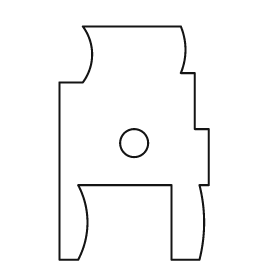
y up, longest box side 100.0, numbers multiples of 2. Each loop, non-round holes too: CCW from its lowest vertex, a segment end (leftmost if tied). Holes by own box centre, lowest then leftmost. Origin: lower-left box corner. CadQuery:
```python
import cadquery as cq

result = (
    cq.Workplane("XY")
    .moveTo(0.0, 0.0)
    .lineTo(8.0, 0.0)
    .threePointArc((12.0, 16.0), (8.0, 32.0))
    .lineTo(48.0, 32.0)
    .lineTo(48.0, 0.0)
    .lineTo(60.0, 0.0)
    .threePointArc((62.0, 16.0), (60.0, 32.0))
    .lineTo(64.0, 32.0)
    .lineTo(64.0, 56.0)
    .lineTo(58.0, 56.0)
    .lineTo(58.0, 80.0)
    .lineTo(52.0, 80.0)
    .threePointArc((54.0, 90.0), (52.0, 100.0))
    .lineTo(10.0, 100.0)
    .threePointArc((14.0, 88.0), (10.0, 76.0))
    .lineTo(0.0, 76.0)
    .close()
    .moveTo(32.0, 50.0)
    .circle(6.0)
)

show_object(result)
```